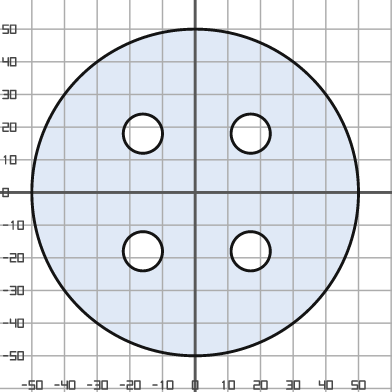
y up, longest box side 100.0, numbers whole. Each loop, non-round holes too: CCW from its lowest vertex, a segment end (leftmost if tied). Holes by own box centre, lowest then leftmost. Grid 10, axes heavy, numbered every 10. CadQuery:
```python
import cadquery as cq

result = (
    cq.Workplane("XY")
    .moveTo(0.0, 0.0)
    .circle(50.0)
    .moveTo(-16.0, -18.0)
    .circle(6.0)
    .moveTo(17.0, -18.0)
    .circle(6.0)
    .moveTo(-16.0, 18.0)
    .circle(6.0)
    .moveTo(17.0, 18.0)
    .circle(6.0)
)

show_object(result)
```